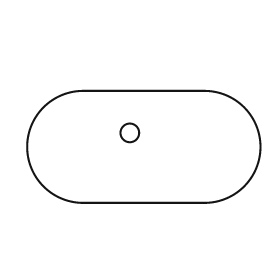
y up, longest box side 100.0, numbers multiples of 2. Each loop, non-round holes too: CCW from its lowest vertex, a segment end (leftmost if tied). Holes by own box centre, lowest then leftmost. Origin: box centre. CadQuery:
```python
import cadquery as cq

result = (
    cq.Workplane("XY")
    .moveTo(-26.0, -24.0)
    .lineTo(26.0, -24.0)
    .threePointArc((50.0, 0.0), (26.0, 24.0))
    .lineTo(-26.0, 24.0)
    .threePointArc((-50.0, 0.0), (-26.0, -24.0))
    .close()
    .moveTo(-6.0, 6.0)
    .circle(4.0)
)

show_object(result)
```